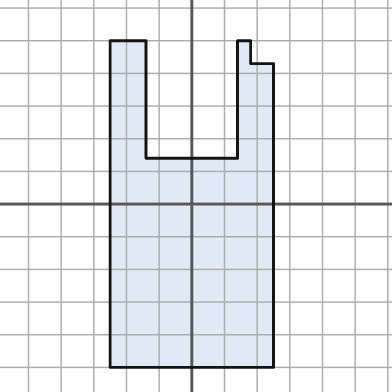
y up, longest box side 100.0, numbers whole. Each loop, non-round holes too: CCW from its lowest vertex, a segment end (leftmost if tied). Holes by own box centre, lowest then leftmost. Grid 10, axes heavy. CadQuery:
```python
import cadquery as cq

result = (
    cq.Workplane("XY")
    .moveTo(-25.0, -50.0)
    .lineTo(25.0, -50.0)
    .lineTo(25.0, 43.0)
    .lineTo(18.0, 43.0)
    .lineTo(18.0, 50.0)
    .lineTo(14.0, 50.0)
    .lineTo(14.0, 14.0)
    .lineTo(-14.0, 14.0)
    .lineTo(-14.0, 50.0)
    .lineTo(-25.0, 50.0)
    .close()
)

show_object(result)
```